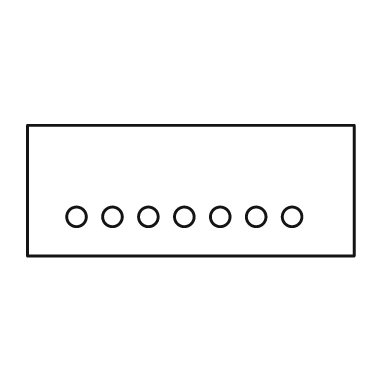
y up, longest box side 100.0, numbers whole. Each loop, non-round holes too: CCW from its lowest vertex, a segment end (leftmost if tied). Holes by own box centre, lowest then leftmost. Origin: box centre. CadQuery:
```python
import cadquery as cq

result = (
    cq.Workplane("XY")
    .moveTo(-50.0, -20.0)
    .lineTo(50.0, -20.0)
    .lineTo(50.0, 20.0)
    .lineTo(-50.0, 20.0)
    .close()
    .moveTo(-35.0, -8.0)
    .circle(3.0)
    .moveTo(-24.0, -8.0)
    .circle(3.0)
    .moveTo(-13.0, -8.0)
    .circle(3.0)
    .moveTo(-2.0, -8.0)
    .circle(3.0)
    .moveTo(9.0, -8.0)
    .circle(3.0)
    .moveTo(20.0, -8.0)
    .circle(3.0)
    .moveTo(31.0, -8.0)
    .circle(3.0)
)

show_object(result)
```